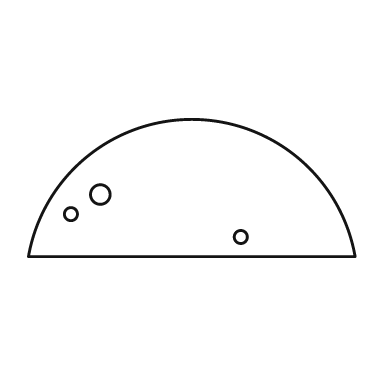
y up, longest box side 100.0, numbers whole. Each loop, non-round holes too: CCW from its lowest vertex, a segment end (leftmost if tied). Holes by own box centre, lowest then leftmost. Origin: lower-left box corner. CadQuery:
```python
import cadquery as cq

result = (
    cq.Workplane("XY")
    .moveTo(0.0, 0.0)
    .lineTo(100.0, 0.0)
    .threePointArc((50.0, 42.0), (0.0, 0.0))
    .close()
    .moveTo(65.0, 6.0)
    .circle(2.0)
    .moveTo(13.0, 13.0)
    .circle(2.0)
    .moveTo(22.0, 19.0)
    .circle(3.0)
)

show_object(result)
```